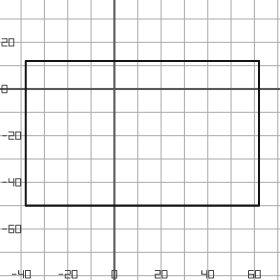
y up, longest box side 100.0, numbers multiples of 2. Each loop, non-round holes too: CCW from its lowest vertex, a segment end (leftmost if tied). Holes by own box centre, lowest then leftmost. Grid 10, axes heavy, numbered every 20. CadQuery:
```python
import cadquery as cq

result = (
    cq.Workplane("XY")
    .moveTo(-38.0, -50.0)
    .lineTo(62.0, -50.0)
    .lineTo(62.0, 12.0)
    .lineTo(-38.0, 12.0)
    .close()
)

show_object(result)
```